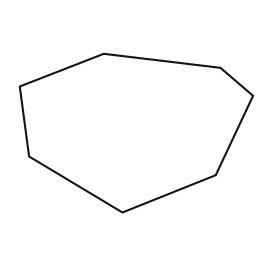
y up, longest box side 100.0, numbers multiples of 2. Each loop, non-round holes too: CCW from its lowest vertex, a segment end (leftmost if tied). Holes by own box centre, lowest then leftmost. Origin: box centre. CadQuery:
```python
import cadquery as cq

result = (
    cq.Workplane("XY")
    .moveTo(-6.0, -34.0)
    .lineTo(34.0, -18.0)
    .lineTo(50.0, 16.0)
    .lineTo(36.0, 28.0)
    .lineTo(-14.0, 34.0)
    .lineTo(-50.0, 20.0)
    .lineTo(-46.0, -10.0)
    .close()
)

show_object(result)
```